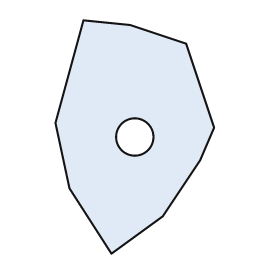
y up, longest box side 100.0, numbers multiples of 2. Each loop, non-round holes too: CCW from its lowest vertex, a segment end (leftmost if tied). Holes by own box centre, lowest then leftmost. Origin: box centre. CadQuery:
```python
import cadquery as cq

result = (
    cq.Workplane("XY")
    .moveTo(-10.0, -50.0)
    .lineTo(12.0, -34.0)
    .lineTo(28.0, -10.0)
    .lineTo(34.0, 4.0)
    .lineTo(22.0, 40.0)
    .lineTo(-2.0, 48.0)
    .lineTo(-22.0, 50.0)
    .lineTo(-34.0, 6.0)
    .lineTo(-28.0, -22.0)
    .close()
    .moveTo(0.0, 0.0)
    .circle(8.0)
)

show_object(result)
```